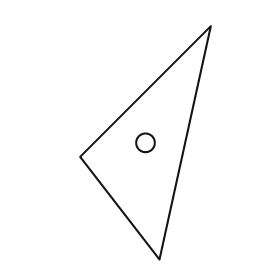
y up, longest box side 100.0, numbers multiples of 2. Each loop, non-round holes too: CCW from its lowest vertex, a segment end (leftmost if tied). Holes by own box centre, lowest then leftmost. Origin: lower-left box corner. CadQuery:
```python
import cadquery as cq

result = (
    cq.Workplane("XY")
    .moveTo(34.0, 0.0)
    .lineTo(56.0, 100.0)
    .lineTo(0.0, 44.0)
    .close()
    .moveTo(28.0, 50.0)
    .circle(4.0)
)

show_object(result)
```